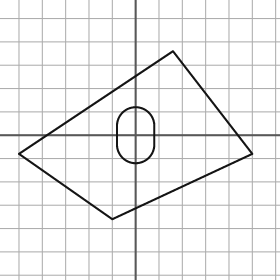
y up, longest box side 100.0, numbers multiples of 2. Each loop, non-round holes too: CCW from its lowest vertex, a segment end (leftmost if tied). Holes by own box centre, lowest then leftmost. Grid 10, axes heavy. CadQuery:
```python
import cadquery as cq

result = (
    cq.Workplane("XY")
    .moveTo(-10.0, -36.0)
    .lineTo(50.0, -8.0)
    .lineTo(16.0, 36.0)
    .lineTo(-50.0, -8.0)
    .close()
    .moveTo(-8.0, -4.0)
    .threePointArc((0.0, -12.0), (8.0, -4.0))
    .lineTo(8.0, 4.0)
    .threePointArc((0.0, 12.0), (-8.0, 4.0))
    .close()
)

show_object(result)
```